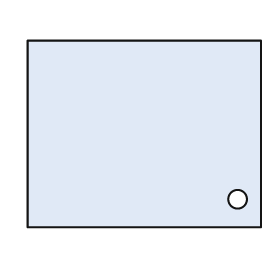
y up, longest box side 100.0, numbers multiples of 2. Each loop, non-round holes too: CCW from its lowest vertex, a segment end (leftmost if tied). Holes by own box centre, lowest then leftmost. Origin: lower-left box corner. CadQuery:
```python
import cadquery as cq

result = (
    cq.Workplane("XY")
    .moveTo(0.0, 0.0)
    .lineTo(100.0, 0.0)
    .lineTo(100.0, 80.0)
    .lineTo(0.0, 80.0)
    .close()
    .moveTo(90.0, 12.0)
    .circle(4.0)
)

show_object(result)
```